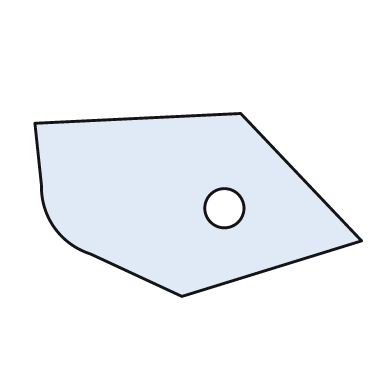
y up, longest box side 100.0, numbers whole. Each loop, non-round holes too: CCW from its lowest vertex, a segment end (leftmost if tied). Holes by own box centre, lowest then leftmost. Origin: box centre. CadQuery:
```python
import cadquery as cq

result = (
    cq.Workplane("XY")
    .moveTo(-5.0, -28.0)
    .lineTo(50.0, -11.0)
    .lineTo(13.0, 28.0)
    .lineTo(-50.0, 25.0)
    .lineTo(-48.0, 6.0)
    .threePointArc((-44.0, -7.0), (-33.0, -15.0))
    .close()
    .moveTo(8.0, -1.0)
    .circle(6.0)
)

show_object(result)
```